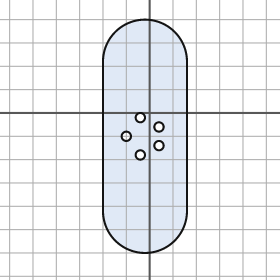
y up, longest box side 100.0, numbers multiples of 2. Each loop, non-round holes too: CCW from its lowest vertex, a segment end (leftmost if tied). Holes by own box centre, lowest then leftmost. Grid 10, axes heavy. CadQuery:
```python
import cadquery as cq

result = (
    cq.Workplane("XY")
    .moveTo(-20.0, -42.0)
    .threePointArc((-2.0, -60.0), (16.0, -42.0))
    .lineTo(16.0, 22.0)
    .threePointArc((-2.0, 40.0), (-20.0, 22.0))
    .close()
    .moveTo(-4.0, -18.0)
    .circle(2.0)
    .moveTo(4.0, -14.0)
    .circle(2.0)
    .moveTo(-10.0, -10.0)
    .circle(2.0)
    .moveTo(4.0, -6.0)
    .circle(2.0)
    .moveTo(-4.0, -2.0)
    .circle(2.0)
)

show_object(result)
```